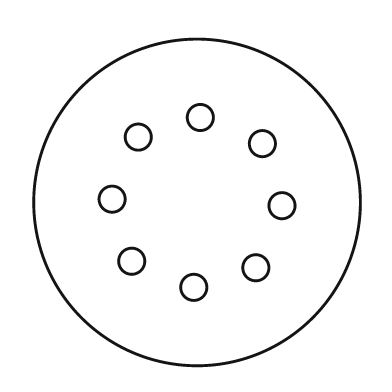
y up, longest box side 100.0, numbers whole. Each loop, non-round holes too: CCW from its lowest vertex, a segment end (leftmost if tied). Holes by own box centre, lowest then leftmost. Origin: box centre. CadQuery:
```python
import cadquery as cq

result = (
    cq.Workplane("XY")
    .moveTo(0.0, 0.0)
    .circle(50.0)
    .moveTo(-1.0, -26.0)
    .circle(4.0)
    .moveTo(18.0, -20.0)
    .circle(4.0)
    .moveTo(-20.0, -18.0)
    .circle(4.0)
    .moveTo(26.0, -1.0)
    .circle(4.0)
    .moveTo(-26.0, 1.0)
    .circle(4.0)
    .moveTo(20.0, 18.0)
    .circle(4.0)
    .moveTo(-18.0, 20.0)
    .circle(4.0)
    .moveTo(1.0, 26.0)
    .circle(4.0)
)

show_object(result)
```